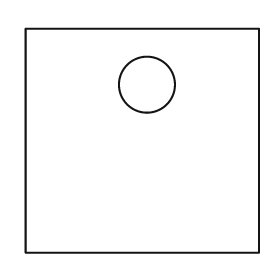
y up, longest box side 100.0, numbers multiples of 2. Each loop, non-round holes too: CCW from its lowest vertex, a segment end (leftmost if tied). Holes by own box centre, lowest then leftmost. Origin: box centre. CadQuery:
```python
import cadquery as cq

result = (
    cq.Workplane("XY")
    .moveTo(-50.0, -48.0)
    .lineTo(50.0, -48.0)
    .lineTo(50.0, 48.0)
    .lineTo(-50.0, 48.0)
    .close()
    .moveTo(2.0, 24.0)
    .circle(12.0)
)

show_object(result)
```